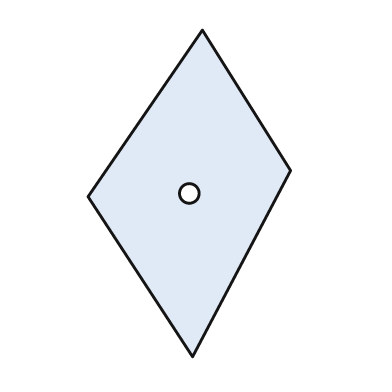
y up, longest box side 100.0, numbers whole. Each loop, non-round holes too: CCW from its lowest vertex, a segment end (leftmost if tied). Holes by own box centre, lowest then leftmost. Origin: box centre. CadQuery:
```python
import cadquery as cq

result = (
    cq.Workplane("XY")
    .moveTo(1.0, -50.0)
    .lineTo(31.0, 7.0)
    .lineTo(4.0, 50.0)
    .lineTo(-31.0, -1.0)
    .close()
    .moveTo(0.0, 0.0)
    .circle(3.0)
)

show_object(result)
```